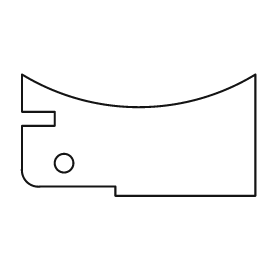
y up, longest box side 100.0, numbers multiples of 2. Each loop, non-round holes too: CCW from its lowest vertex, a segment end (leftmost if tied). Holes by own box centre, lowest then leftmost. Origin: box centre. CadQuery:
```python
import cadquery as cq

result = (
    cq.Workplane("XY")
    .moveTo(-10.0, -26.0)
    .lineTo(50.0, -26.0)
    .lineTo(50.0, 26.0)
    .threePointArc((0.0, 12.0), (-50.0, 26.0))
    .lineTo(-50.0, 10.0)
    .lineTo(-36.0, 10.0)
    .lineTo(-36.0, 4.0)
    .lineTo(-50.0, 4.0)
    .lineTo(-50.0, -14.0)
    .threePointArc((-48.0, -20.0), (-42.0, -22.0))
    .lineTo(-10.0, -22.0)
    .close()
    .moveTo(-32.0, -12.0)
    .circle(4.0)
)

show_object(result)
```